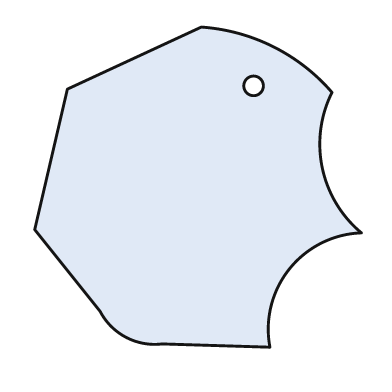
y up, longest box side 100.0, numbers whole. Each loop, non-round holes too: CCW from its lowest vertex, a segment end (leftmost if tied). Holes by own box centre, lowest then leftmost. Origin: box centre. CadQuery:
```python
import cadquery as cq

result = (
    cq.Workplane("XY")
    .moveTo(22.0, -49.0)
    .threePointArc((28.0, -25.0), (50.0, -14.0))
    .threePointArc((38.0, 6.0), (41.0, 29.0))
    .threePointArc((23.0, 43.0), (1.0, 49.0))
    .lineTo(-40.0, 30.0)
    .lineTo(-50.0, -13.0)
    .lineTo(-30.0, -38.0)
    .threePointArc((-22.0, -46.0), (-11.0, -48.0))
    .close()
    .moveTo(17.0, 31.0)
    .circle(3.0)
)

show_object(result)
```